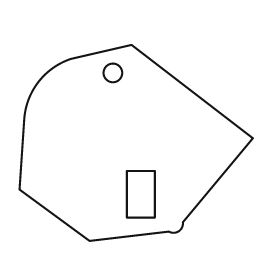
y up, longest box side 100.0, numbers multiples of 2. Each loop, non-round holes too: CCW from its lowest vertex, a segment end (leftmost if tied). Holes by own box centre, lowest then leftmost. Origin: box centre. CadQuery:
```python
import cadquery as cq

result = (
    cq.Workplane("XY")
    .moveTo(-20.0, -42.0)
    .lineTo(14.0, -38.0)
    .threePointArc((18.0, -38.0), (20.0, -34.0))
    .lineTo(50.0, 2.0)
    .lineTo(-2.0, 42.0)
    .lineTo(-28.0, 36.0)
    .threePointArc((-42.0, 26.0), (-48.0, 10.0))
    .lineTo(-50.0, -20.0)
    .close()
    .moveTo(-4.0, -32.0)
    .lineTo(8.0, -32.0)
    .lineTo(8.0, -12.0)
    .lineTo(-4.0, -12.0)
    .close()
    .moveTo(-10.0, 30.0)
    .circle(4.0)
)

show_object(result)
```